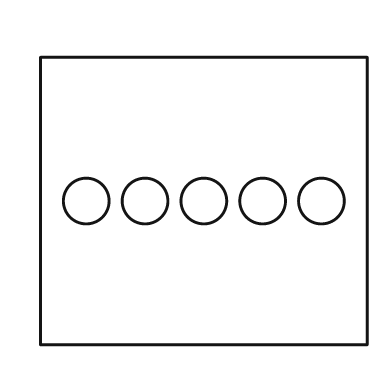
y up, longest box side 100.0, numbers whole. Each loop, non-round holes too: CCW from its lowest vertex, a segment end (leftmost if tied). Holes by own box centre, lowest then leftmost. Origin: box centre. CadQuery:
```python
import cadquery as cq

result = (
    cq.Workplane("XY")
    .moveTo(-50.0, -44.0)
    .lineTo(50.0, -44.0)
    .lineTo(50.0, 44.0)
    .lineTo(-50.0, 44.0)
    .close()
    .moveTo(-36.0, 0.0)
    .circle(7.0)
    .moveTo(-18.0, 0.0)
    .circle(7.0)
    .moveTo(0.0, 0.0)
    .circle(7.0)
    .moveTo(18.0, 0.0)
    .circle(7.0)
    .moveTo(36.0, 0.0)
    .circle(7.0)
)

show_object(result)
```